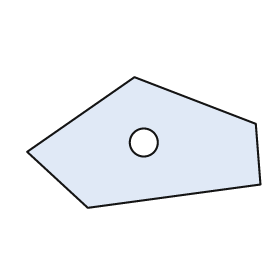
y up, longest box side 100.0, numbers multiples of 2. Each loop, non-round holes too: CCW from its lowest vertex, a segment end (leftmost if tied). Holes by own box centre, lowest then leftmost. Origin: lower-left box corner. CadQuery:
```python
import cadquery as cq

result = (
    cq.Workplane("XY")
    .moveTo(26.0, 0.0)
    .lineTo(100.0, 10.0)
    .lineTo(98.0, 36.0)
    .lineTo(46.0, 56.0)
    .lineTo(0.0, 24.0)
    .close()
    .moveTo(50.0, 28.0)
    .circle(6.0)
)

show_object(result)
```